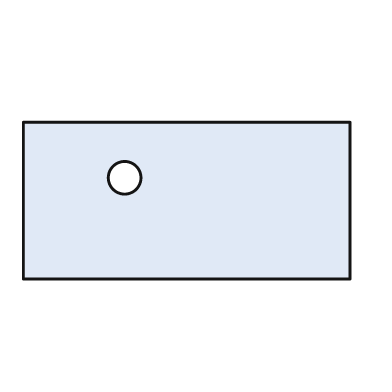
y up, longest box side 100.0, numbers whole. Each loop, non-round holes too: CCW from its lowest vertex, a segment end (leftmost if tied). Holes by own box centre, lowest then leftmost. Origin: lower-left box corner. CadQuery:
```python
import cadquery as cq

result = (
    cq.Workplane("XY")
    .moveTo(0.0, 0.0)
    .lineTo(100.0, 0.0)
    .lineTo(100.0, 48.0)
    .lineTo(0.0, 48.0)
    .close()
    .moveTo(31.0, 31.0)
    .circle(5.0)
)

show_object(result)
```